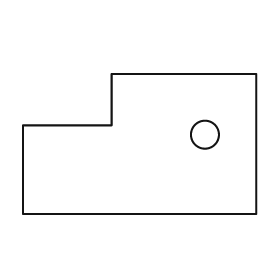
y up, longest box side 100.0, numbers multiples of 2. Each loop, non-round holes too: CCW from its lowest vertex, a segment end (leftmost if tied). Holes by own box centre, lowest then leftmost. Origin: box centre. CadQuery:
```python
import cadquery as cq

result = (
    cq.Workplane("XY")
    .moveTo(-50.0, -30.0)
    .lineTo(50.0, -30.0)
    .lineTo(50.0, 30.0)
    .lineTo(-12.0, 30.0)
    .lineTo(-12.0, 8.0)
    .lineTo(-50.0, 8.0)
    .close()
    .moveTo(28.0, 4.0)
    .circle(6.0)
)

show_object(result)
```